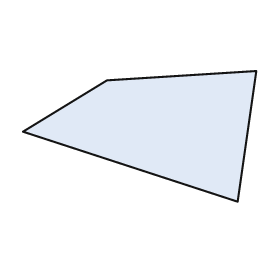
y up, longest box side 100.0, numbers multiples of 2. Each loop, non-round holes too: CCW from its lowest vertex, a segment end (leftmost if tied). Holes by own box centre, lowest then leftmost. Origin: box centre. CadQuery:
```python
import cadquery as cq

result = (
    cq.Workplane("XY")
    .moveTo(42.0, -28.0)
    .lineTo(50.0, 28.0)
    .lineTo(-14.0, 24.0)
    .lineTo(-50.0, 2.0)
    .close()
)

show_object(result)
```